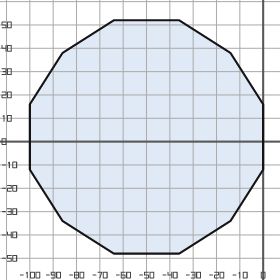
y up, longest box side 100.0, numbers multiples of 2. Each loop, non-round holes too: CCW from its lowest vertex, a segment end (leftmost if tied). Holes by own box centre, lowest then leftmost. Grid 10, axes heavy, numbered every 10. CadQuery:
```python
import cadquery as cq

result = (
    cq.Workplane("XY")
    .moveTo(-64.0, -48.0)
    .lineTo(-36.0, -48.0)
    .lineTo(-14.0, -34.0)
    .lineTo(0.0, -12.0)
    .lineTo(0.0, 16.0)
    .lineTo(-14.0, 38.0)
    .lineTo(-36.0, 52.0)
    .lineTo(-64.0, 52.0)
    .lineTo(-86.0, 38.0)
    .lineTo(-100.0, 16.0)
    .lineTo(-100.0, -12.0)
    .lineTo(-86.0, -34.0)
    .close()
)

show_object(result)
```